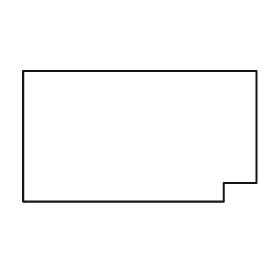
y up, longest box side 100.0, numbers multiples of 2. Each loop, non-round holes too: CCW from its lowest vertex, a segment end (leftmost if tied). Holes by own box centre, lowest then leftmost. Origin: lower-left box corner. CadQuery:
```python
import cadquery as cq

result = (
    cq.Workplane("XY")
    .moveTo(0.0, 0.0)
    .lineTo(86.0, 0.0)
    .lineTo(86.0, 8.0)
    .lineTo(100.0, 8.0)
    .lineTo(100.0, 56.0)
    .lineTo(0.0, 56.0)
    .close()
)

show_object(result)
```